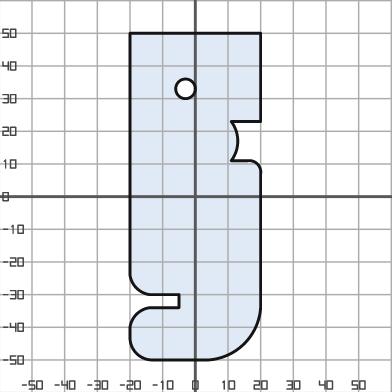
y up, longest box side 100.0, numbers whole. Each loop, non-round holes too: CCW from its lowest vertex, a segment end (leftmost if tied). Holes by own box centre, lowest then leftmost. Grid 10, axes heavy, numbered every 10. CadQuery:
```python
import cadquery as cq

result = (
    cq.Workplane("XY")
    .moveTo(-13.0, -50.0)
    .lineTo(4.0, -50.0)
    .threePointArc((15.0, -45.0), (20.0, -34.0))
    .lineTo(20.0, 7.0)
    .threePointArc((19.0, 10.0), (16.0, 11.0))
    .lineTo(11.0, 11.0)
    .threePointArc((13.0, 17.0), (11.0, 23.0))
    .lineTo(20.0, 23.0)
    .lineTo(20.0, 50.0)
    .lineTo(-20.0, 50.0)
    .lineTo(-20.0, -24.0)
    .threePointArc((-18.0, -28.0), (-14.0, -30.0))
    .lineTo(-5.0, -30.0)
    .lineTo(-5.0, -34.0)
    .lineTo(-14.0, -34.0)
    .threePointArc((-18.0, -36.0), (-20.0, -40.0))
    .lineTo(-20.0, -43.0)
    .threePointArc((-18.0, -48.0), (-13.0, -50.0))
    .close()
    .moveTo(-3.0, 33.0)
    .circle(3.0)
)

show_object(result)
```